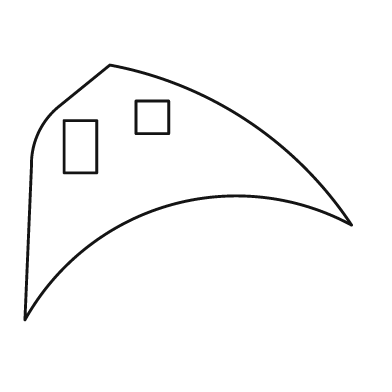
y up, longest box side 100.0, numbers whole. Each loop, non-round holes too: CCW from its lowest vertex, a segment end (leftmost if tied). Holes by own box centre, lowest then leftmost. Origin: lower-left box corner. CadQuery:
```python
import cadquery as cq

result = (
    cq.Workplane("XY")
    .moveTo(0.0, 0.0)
    .threePointArc((44.0, 35.0), (100.0, 29.0))
    .threePointArc((68.0, 61.0), (26.0, 78.0))
    .lineTo(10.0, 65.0)
    .threePointArc((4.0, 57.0), (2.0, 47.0))
    .close()
    .moveTo(12.0, 45.0)
    .lineTo(22.0, 45.0)
    .lineTo(22.0, 61.0)
    .lineTo(12.0, 61.0)
    .close()
    .moveTo(34.0, 57.0)
    .lineTo(44.0, 57.0)
    .lineTo(44.0, 67.0)
    .lineTo(34.0, 67.0)
    .close()
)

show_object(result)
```